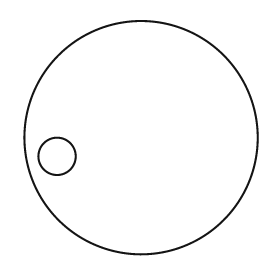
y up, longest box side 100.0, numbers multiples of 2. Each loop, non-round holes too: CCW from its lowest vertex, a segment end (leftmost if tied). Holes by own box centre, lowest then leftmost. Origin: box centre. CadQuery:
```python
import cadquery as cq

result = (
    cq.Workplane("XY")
    .moveTo(0.0, 0.0)
    .circle(50.0)
    .moveTo(-36.0, -8.0)
    .circle(8.0)
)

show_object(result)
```